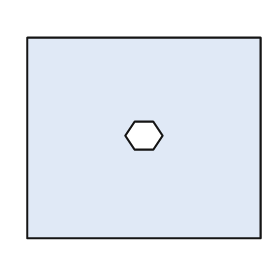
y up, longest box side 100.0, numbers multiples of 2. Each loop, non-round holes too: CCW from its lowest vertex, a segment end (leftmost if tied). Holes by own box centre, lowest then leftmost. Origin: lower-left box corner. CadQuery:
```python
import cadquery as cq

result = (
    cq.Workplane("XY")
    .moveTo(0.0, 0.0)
    .lineTo(100.0, 0.0)
    .lineTo(100.0, 86.0)
    .lineTo(0.0, 86.0)
    .close()
    .moveTo(46.0, 38.0)
    .lineTo(54.0, 38.0)
    .lineTo(58.0, 44.0)
    .lineTo(54.0, 50.0)
    .lineTo(46.0, 50.0)
    .lineTo(42.0, 44.0)
    .close()
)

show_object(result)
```